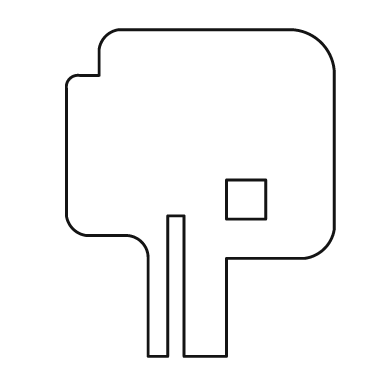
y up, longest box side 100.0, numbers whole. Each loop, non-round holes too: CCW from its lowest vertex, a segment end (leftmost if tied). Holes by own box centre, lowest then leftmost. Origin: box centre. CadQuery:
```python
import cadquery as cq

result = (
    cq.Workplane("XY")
    .moveTo(-16.0, -50.0)
    .lineTo(-10.0, -50.0)
    .lineTo(-10.0, -7.0)
    .lineTo(-5.0, -7.0)
    .lineTo(-5.0, -50.0)
    .lineTo(8.0, -50.0)
    .lineTo(8.0, -20.0)
    .lineTo(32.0, -20.0)
    .threePointArc((38.0, -17.0), (41.0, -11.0))
    .lineTo(41.0, 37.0)
    .threePointArc((37.0, 46.0), (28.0, 50.0))
    .lineTo(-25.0, 50.0)
    .threePointArc((-29.0, 48.0), (-31.0, 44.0))
    .lineTo(-31.0, 36.0)
    .lineTo(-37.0, 36.0)
    .threePointArc((-40.0, 35.0), (-41.0, 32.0))
    .lineTo(-41.0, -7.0)
    .threePointArc((-39.0, -11.0), (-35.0, -13.0))
    .lineTo(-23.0, -13.0)
    .threePointArc((-18.0, -15.0), (-16.0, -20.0))
    .close()
    .moveTo(8.0, -8.0)
    .lineTo(20.0, -8.0)
    .lineTo(20.0, 4.0)
    .lineTo(8.0, 4.0)
    .close()
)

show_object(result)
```